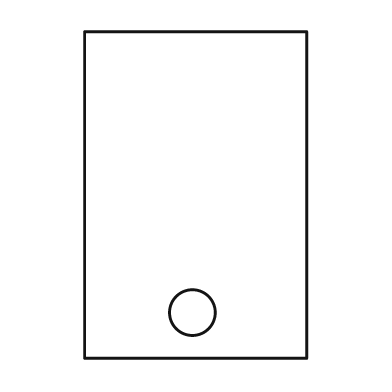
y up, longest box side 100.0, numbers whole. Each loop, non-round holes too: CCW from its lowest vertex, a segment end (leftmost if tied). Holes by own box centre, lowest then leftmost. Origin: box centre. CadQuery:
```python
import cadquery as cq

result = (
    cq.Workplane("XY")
    .moveTo(-34.0, -50.0)
    .lineTo(34.0, -50.0)
    .lineTo(34.0, 50.0)
    .lineTo(-34.0, 50.0)
    .close()
    .moveTo(-1.0, -36.0)
    .circle(7.0)
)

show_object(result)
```